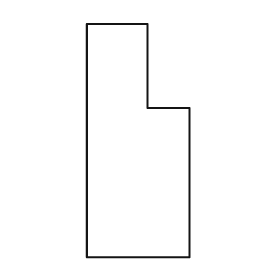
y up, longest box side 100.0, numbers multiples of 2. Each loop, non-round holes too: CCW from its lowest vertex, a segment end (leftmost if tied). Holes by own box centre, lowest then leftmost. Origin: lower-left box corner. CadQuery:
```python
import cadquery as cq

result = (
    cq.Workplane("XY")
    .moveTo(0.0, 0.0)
    .lineTo(44.0, 0.0)
    .lineTo(44.0, 64.0)
    .lineTo(26.0, 64.0)
    .lineTo(26.0, 100.0)
    .lineTo(0.0, 100.0)
    .close()
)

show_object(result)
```